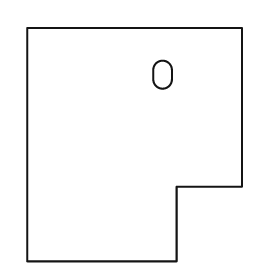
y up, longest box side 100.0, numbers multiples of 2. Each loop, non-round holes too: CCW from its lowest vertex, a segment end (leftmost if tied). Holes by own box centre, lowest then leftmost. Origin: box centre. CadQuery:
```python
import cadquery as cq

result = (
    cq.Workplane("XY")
    .moveTo(-46.0, -50.0)
    .lineTo(18.0, -50.0)
    .lineTo(18.0, -18.0)
    .lineTo(46.0, -18.0)
    .lineTo(46.0, 50.0)
    .lineTo(-46.0, 50.0)
    .close()
    .moveTo(8.0, 28.0)
    .threePointArc((12.0, 24.0), (16.0, 28.0))
    .lineTo(16.0, 32.0)
    .threePointArc((12.0, 36.0), (8.0, 32.0))
    .close()
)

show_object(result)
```